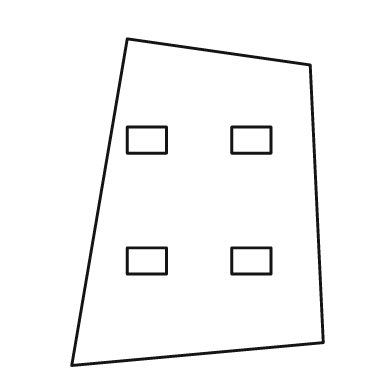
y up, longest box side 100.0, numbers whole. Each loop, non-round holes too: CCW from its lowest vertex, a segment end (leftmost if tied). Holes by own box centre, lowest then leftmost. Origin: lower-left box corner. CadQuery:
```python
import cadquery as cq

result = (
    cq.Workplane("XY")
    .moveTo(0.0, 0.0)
    .lineTo(77.0, 7.0)
    .lineTo(73.0, 92.0)
    .lineTo(17.0, 100.0)
    .close()
    .moveTo(17.0, 28.0)
    .lineTo(29.0, 28.0)
    .lineTo(29.0, 36.0)
    .lineTo(17.0, 36.0)
    .close()
    .moveTo(49.0, 28.0)
    .lineTo(61.0, 28.0)
    .lineTo(61.0, 36.0)
    .lineTo(49.0, 36.0)
    .close()
    .moveTo(17.0, 65.0)
    .lineTo(29.0, 65.0)
    .lineTo(29.0, 73.0)
    .lineTo(17.0, 73.0)
    .close()
    .moveTo(49.0, 65.0)
    .lineTo(61.0, 65.0)
    .lineTo(61.0, 73.0)
    .lineTo(49.0, 73.0)
    .close()
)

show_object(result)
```